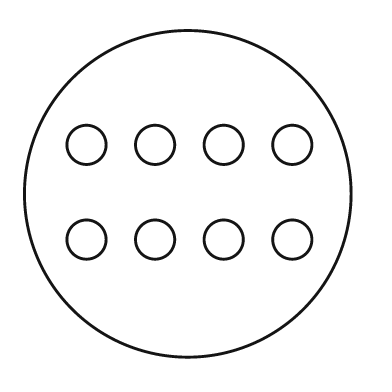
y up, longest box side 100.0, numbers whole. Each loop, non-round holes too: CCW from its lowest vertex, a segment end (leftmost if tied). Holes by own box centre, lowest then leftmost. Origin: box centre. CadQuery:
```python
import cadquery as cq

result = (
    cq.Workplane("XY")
    .moveTo(0.0, 0.0)
    .circle(50.0)
    .moveTo(-31.0, -14.0)
    .circle(6.0)
    .moveTo(-10.0, -14.0)
    .circle(6.0)
    .moveTo(11.0, -14.0)
    .circle(6.0)
    .moveTo(32.0, -14.0)
    .circle(6.0)
    .moveTo(-31.0, 15.0)
    .circle(6.0)
    .moveTo(-10.0, 15.0)
    .circle(6.0)
    .moveTo(11.0, 15.0)
    .circle(6.0)
    .moveTo(32.0, 15.0)
    .circle(6.0)
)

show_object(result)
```